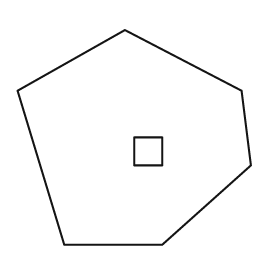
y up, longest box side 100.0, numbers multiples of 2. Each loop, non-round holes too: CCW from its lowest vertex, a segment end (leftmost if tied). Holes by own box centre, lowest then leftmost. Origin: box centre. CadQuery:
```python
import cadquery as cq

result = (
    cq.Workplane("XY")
    .moveTo(-30.0, -46.0)
    .lineTo(12.0, -46.0)
    .lineTo(50.0, -12.0)
    .lineTo(46.0, 20.0)
    .lineTo(-4.0, 46.0)
    .lineTo(-50.0, 20.0)
    .close()
    .moveTo(0.0, -12.0)
    .lineTo(12.0, -12.0)
    .lineTo(12.0, 0.0)
    .lineTo(0.0, 0.0)
    .close()
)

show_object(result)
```